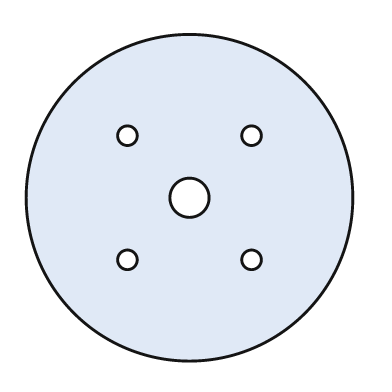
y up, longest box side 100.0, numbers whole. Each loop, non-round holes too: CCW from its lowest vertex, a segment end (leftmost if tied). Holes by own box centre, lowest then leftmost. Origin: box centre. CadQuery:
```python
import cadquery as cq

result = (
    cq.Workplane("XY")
    .moveTo(0.0, 0.0)
    .circle(50.0)
    .moveTo(-19.0, -19.0)
    .circle(3.0)
    .moveTo(19.0, -19.0)
    .circle(3.0)
    .moveTo(0.0, 0.0)
    .circle(6.0)
    .moveTo(-19.0, 19.0)
    .circle(3.0)
    .moveTo(19.0, 19.0)
    .circle(3.0)
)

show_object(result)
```